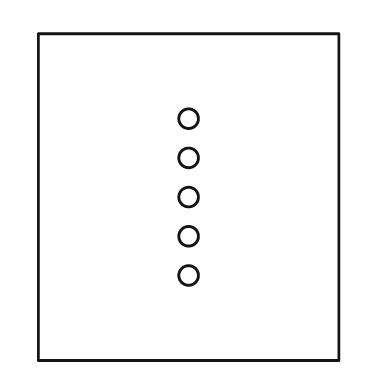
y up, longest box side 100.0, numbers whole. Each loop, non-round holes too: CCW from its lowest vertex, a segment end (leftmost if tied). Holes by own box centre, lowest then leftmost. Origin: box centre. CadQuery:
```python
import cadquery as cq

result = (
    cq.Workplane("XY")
    .moveTo(-46.0, -50.0)
    .lineTo(46.0, -50.0)
    .lineTo(46.0, 50.0)
    .lineTo(-46.0, 50.0)
    .close()
    .moveTo(0.0, -24.0)
    .circle(3.0)
    .moveTo(0.0, -12.0)
    .circle(3.0)
    .moveTo(0.0, 0.0)
    .circle(3.0)
    .moveTo(0.0, 12.0)
    .circle(3.0)
    .moveTo(0.0, 24.0)
    .circle(3.0)
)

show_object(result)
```